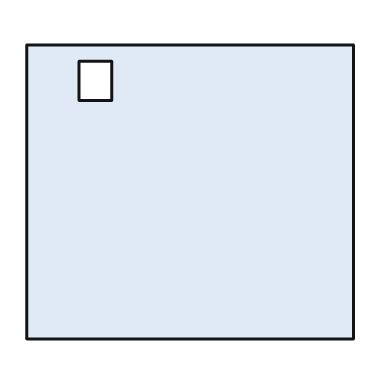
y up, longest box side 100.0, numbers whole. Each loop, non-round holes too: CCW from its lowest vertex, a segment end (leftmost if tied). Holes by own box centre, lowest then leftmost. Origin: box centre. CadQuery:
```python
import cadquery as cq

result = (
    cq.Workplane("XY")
    .moveTo(-50.0, -45.0)
    .lineTo(50.0, -45.0)
    .lineTo(50.0, 45.0)
    .lineTo(-50.0, 45.0)
    .close()
    .moveTo(-34.0, 28.0)
    .lineTo(-24.0, 28.0)
    .lineTo(-24.0, 40.0)
    .lineTo(-34.0, 40.0)
    .close()
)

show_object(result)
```